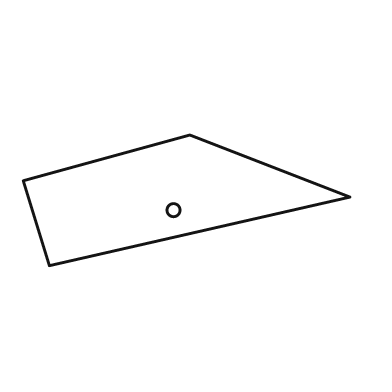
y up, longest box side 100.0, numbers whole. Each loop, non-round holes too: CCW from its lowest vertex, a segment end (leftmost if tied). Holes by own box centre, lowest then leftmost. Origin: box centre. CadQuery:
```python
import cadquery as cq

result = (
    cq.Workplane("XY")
    .moveTo(-42.0, -20.0)
    .lineTo(50.0, 1.0)
    .lineTo(1.0, 20.0)
    .lineTo(-50.0, 6.0)
    .close()
    .moveTo(-4.0, -3.0)
    .circle(2.0)
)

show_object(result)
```